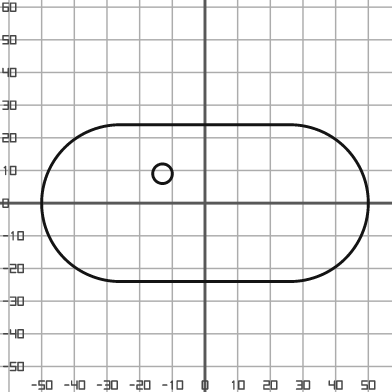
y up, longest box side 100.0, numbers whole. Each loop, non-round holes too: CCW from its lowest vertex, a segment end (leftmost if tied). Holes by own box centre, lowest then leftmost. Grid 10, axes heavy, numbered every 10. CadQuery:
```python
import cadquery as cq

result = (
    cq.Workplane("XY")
    .moveTo(-26.0, -24.0)
    .lineTo(26.0, -24.0)
    .threePointArc((50.0, 0.0), (26.0, 24.0))
    .lineTo(-26.0, 24.0)
    .threePointArc((-50.0, 0.0), (-26.0, -24.0))
    .close()
    .moveTo(-13.0, 9.0)
    .circle(3.0)
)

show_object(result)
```